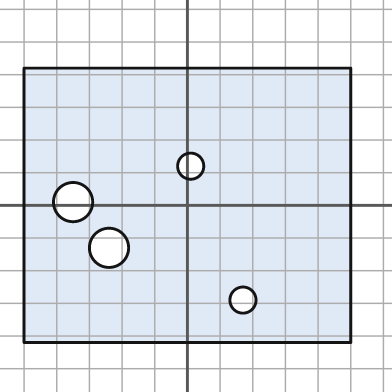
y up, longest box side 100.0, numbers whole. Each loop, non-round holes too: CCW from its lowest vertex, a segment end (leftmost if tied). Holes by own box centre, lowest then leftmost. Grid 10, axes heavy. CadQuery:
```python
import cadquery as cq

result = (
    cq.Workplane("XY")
    .moveTo(-50.0, -42.0)
    .lineTo(50.0, -42.0)
    .lineTo(50.0, 42.0)
    .lineTo(-50.0, 42.0)
    .close()
    .moveTo(17.0, -29.0)
    .circle(4.0)
    .moveTo(-24.0, -13.0)
    .circle(6.0)
    .moveTo(-35.0, 1.0)
    .circle(6.0)
    .moveTo(1.0, 12.0)
    .circle(4.0)
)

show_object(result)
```